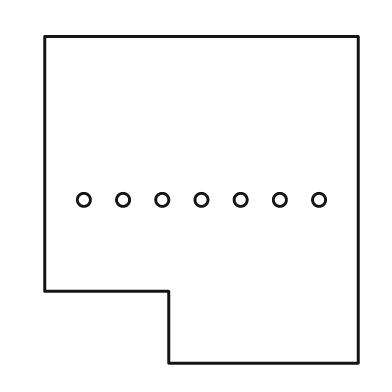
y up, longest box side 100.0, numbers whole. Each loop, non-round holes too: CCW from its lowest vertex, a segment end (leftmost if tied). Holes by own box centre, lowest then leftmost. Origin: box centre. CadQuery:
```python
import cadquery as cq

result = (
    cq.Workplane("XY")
    .moveTo(-10.0, -50.0)
    .lineTo(48.0, -50.0)
    .lineTo(48.0, 50.0)
    .lineTo(-48.0, 50.0)
    .lineTo(-48.0, -28.0)
    .lineTo(-10.0, -28.0)
    .close()
    .moveTo(-36.0, 0.0)
    .circle(2.0)
    .moveTo(-24.0, 0.0)
    .circle(2.0)
    .moveTo(-12.0, 0.0)
    .circle(2.0)
    .moveTo(0.0, 0.0)
    .circle(2.0)
    .moveTo(12.0, 0.0)
    .circle(2.0)
    .moveTo(24.0, 0.0)
    .circle(2.0)
    .moveTo(36.0, 0.0)
    .circle(2.0)
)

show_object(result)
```